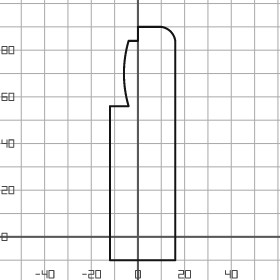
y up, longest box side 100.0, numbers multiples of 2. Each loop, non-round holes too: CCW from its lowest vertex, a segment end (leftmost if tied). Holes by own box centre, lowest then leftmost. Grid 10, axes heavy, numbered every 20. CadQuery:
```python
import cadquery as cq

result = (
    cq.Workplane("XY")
    .moveTo(-12.0, -10.0)
    .lineTo(16.0, -10.0)
    .lineTo(16.0, 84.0)
    .threePointArc((14.0, 88.0), (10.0, 90.0))
    .lineTo(0.0, 90.0)
    .lineTo(0.0, 84.0)
    .lineTo(-4.0, 84.0)
    .threePointArc((-6.0, 70.0), (-4.0, 56.0))
    .lineTo(-12.0, 56.0)
    .close()
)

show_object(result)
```